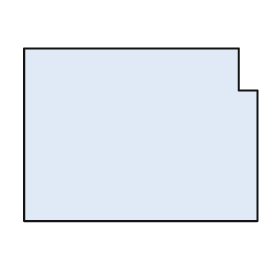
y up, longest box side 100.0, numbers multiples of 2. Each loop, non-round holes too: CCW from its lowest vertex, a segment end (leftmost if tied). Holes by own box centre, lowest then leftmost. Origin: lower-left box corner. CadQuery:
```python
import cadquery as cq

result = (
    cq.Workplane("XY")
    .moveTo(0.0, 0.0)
    .lineTo(100.0, 0.0)
    .lineTo(100.0, 56.0)
    .lineTo(92.0, 56.0)
    .lineTo(92.0, 74.0)
    .lineTo(0.0, 74.0)
    .close()
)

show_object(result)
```